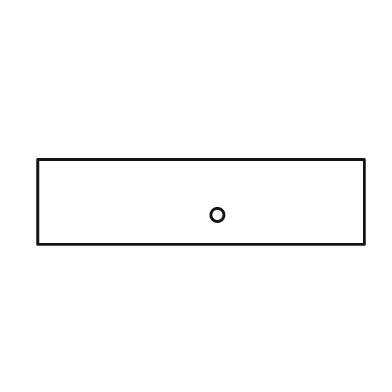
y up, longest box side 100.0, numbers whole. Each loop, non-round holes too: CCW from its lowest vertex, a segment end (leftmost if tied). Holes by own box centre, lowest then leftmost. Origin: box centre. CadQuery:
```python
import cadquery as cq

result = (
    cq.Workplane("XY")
    .moveTo(-50.0, -13.0)
    .lineTo(50.0, -13.0)
    .lineTo(50.0, 13.0)
    .lineTo(-50.0, 13.0)
    .close()
    .moveTo(5.0, -4.0)
    .circle(2.0)
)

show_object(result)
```